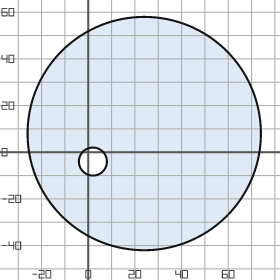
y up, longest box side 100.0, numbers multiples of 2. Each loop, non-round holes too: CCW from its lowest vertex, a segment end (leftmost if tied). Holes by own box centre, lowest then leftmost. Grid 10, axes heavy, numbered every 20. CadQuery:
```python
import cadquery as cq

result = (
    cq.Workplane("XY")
    .moveTo(24.0, 8.0)
    .circle(50.0)
    .moveTo(2.0, -4.0)
    .circle(6.0)
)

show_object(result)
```